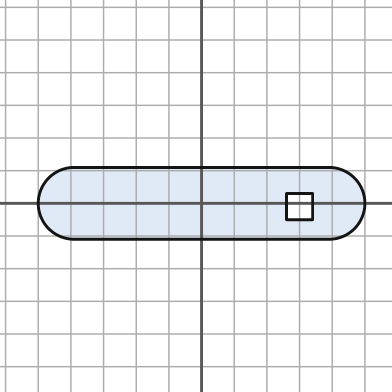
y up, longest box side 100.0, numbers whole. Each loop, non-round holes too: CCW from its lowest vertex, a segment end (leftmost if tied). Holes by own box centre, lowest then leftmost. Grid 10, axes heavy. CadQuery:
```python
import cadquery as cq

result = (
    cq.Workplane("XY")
    .moveTo(-39.0, -11.0)
    .lineTo(39.0, -11.0)
    .threePointArc((50.0, 0.0), (39.0, 11.0))
    .lineTo(-39.0, 11.0)
    .threePointArc((-50.0, 0.0), (-39.0, -11.0))
    .close()
    .moveTo(26.0, -5.0)
    .lineTo(34.0, -5.0)
    .lineTo(34.0, 3.0)
    .lineTo(26.0, 3.0)
    .close()
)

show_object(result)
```